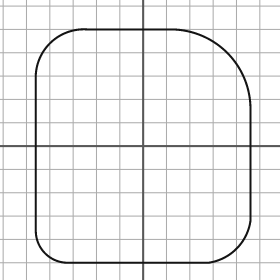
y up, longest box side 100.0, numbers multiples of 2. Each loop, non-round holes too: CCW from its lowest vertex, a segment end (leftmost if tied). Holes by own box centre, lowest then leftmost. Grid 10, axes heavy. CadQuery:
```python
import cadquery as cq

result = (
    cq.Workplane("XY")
    .moveTo(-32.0, -50.0)
    .lineTo(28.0, -50.0)
    .threePointArc((40.0, -44.0), (46.0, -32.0))
    .lineTo(46.0, 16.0)
    .threePointArc((36.0, 40.0), (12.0, 50.0))
    .lineTo(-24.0, 50.0)
    .threePointArc((-40.0, 44.0), (-46.0, 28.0))
    .lineTo(-46.0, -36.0)
    .threePointArc((-42.0, -46.0), (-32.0, -50.0))
    .close()
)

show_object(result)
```